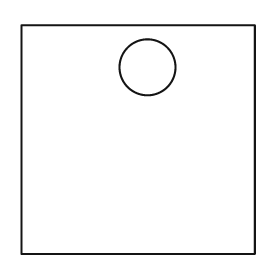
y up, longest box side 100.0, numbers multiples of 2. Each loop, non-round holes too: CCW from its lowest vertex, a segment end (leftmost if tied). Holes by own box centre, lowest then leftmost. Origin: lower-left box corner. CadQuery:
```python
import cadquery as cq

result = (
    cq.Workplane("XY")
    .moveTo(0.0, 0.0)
    .lineTo(100.0, 0.0)
    .lineTo(100.0, 98.0)
    .lineTo(0.0, 98.0)
    .close()
    .moveTo(54.0, 80.0)
    .circle(12.0)
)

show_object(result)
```